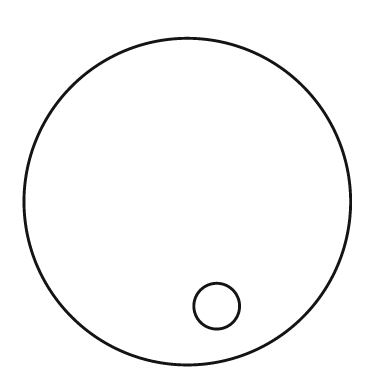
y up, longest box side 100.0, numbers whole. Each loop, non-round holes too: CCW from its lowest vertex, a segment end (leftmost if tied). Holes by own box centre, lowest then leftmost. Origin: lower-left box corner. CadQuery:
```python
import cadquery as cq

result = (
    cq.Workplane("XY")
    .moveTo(50.0, 50.0)
    .circle(50.0)
    .moveTo(59.0, 18.0)
    .circle(7.0)
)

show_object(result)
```